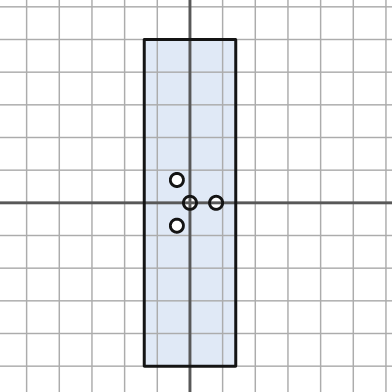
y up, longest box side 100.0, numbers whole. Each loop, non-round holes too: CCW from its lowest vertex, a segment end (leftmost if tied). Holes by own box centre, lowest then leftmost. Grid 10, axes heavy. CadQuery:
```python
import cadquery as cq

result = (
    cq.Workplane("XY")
    .moveTo(-14.0, -50.0)
    .lineTo(14.0, -50.0)
    .lineTo(14.0, 50.0)
    .lineTo(-14.0, 50.0)
    .close()
    .moveTo(-4.0, -7.0)
    .circle(2.0)
    .moveTo(0.0, 0.0)
    .circle(2.0)
    .moveTo(8.0, 0.0)
    .circle(2.0)
    .moveTo(-4.0, 7.0)
    .circle(2.0)
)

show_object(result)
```